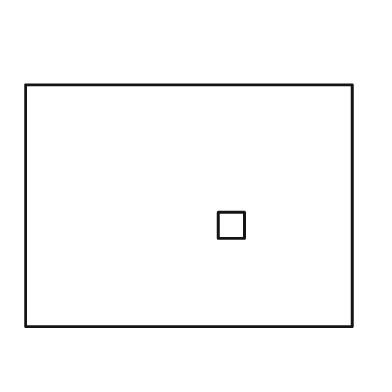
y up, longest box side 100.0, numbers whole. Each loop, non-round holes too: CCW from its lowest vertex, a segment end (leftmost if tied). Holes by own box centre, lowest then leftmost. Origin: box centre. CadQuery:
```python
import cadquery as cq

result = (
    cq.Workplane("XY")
    .moveTo(-50.0, -37.0)
    .lineTo(50.0, -37.0)
    .lineTo(50.0, 37.0)
    .lineTo(-50.0, 37.0)
    .close()
    .moveTo(9.0, -10.0)
    .lineTo(17.0, -10.0)
    .lineTo(17.0, -2.0)
    .lineTo(9.0, -2.0)
    .close()
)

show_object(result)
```